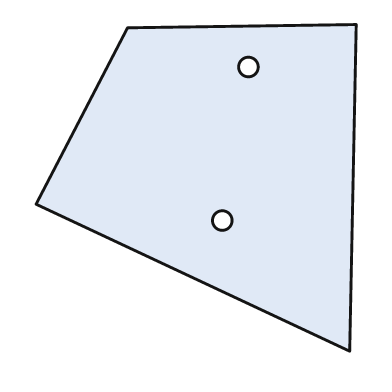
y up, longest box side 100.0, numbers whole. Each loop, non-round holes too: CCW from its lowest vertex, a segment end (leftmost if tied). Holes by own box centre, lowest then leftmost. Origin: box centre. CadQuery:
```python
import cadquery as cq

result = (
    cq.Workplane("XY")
    .moveTo(47.0, -50.0)
    .lineTo(49.0, 50.0)
    .lineTo(-21.0, 49.0)
    .lineTo(-49.0, -5.0)
    .close()
    .moveTo(8.0, -10.0)
    .circle(3.0)
    .moveTo(16.0, 37.0)
    .circle(3.0)
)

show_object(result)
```